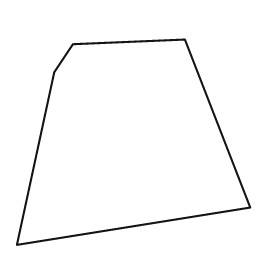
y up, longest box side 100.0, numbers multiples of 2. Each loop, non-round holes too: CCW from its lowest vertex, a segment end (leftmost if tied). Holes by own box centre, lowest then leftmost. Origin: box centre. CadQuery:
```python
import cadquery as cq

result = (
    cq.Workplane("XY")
    .moveTo(-50.0, -44.0)
    .lineTo(50.0, -28.0)
    .lineTo(22.0, 44.0)
    .lineTo(-26.0, 42.0)
    .lineTo(-34.0, 30.0)
    .close()
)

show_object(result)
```